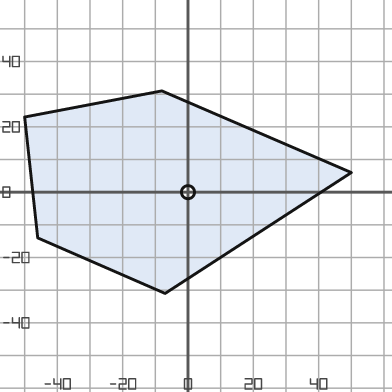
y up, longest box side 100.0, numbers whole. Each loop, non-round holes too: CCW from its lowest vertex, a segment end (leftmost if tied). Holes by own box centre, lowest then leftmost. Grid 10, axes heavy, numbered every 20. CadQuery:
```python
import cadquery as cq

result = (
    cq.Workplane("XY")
    .moveTo(-7.0, -31.0)
    .lineTo(50.0, 6.0)
    .lineTo(-8.0, 31.0)
    .lineTo(-50.0, 23.0)
    .lineTo(-46.0, -14.0)
    .close()
    .moveTo(0.0, 0.0)
    .circle(2.0)
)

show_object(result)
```